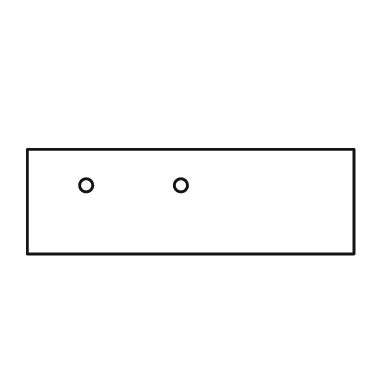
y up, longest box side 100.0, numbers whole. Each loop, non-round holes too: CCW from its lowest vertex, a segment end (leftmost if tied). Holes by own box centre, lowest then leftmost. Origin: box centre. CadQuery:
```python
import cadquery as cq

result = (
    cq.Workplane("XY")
    .moveTo(-50.0, -16.0)
    .lineTo(50.0, -16.0)
    .lineTo(50.0, 16.0)
    .lineTo(-50.0, 16.0)
    .close()
    .moveTo(-32.0, 5.0)
    .circle(2.0)
    .moveTo(-3.0, 5.0)
    .circle(2.0)
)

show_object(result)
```